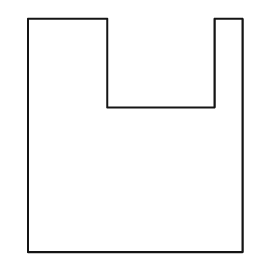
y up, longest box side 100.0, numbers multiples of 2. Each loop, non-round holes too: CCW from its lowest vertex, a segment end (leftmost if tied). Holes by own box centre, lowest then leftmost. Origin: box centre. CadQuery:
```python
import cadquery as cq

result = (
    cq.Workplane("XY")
    .moveTo(-46.0, -50.0)
    .lineTo(46.0, -50.0)
    .lineTo(46.0, 50.0)
    .lineTo(34.0, 50.0)
    .lineTo(34.0, 12.0)
    .lineTo(-12.0, 12.0)
    .lineTo(-12.0, 50.0)
    .lineTo(-46.0, 50.0)
    .close()
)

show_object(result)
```